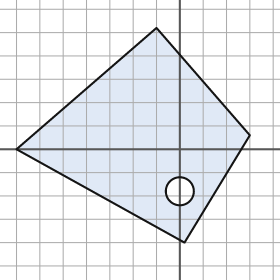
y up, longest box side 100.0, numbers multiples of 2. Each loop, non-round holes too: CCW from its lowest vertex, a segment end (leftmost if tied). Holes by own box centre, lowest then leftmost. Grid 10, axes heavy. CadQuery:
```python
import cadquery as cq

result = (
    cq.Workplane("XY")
    .moveTo(2.0, -40.0)
    .lineTo(30.0, 6.0)
    .lineTo(-10.0, 52.0)
    .lineTo(-70.0, 0.0)
    .close()
    .moveTo(0.0, -18.0)
    .circle(6.0)
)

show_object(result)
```